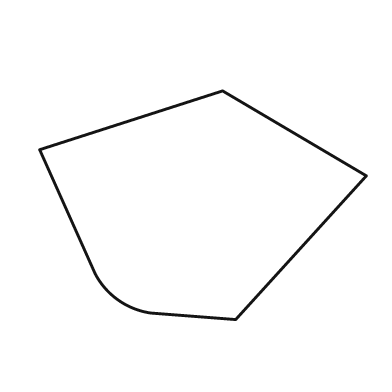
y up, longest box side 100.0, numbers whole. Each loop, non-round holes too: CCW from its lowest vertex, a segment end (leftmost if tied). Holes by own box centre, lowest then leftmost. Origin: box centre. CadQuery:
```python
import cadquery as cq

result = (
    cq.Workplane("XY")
    .moveTo(10.0, -35.0)
    .lineTo(50.0, 9.0)
    .lineTo(6.0, 35.0)
    .lineTo(-50.0, 17.0)
    .lineTo(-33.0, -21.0)
    .threePointArc((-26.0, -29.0), (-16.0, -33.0))
    .close()
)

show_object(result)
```